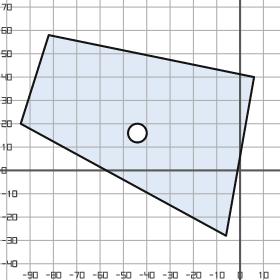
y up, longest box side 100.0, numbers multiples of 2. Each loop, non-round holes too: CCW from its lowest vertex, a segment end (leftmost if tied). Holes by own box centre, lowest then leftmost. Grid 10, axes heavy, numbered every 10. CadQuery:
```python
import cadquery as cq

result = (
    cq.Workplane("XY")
    .moveTo(-6.0, -28.0)
    .lineTo(6.0, 40.0)
    .lineTo(-82.0, 58.0)
    .lineTo(-94.0, 20.0)
    .close()
    .moveTo(-44.0, 16.0)
    .circle(4.0)
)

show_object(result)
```